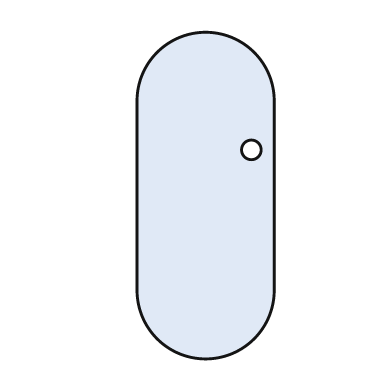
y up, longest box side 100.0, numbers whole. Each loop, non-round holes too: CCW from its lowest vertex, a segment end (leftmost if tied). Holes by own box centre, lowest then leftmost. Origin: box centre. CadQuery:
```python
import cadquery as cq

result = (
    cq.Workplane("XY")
    .moveTo(-21.0, -29.0)
    .threePointArc((0.0, -50.0), (21.0, -29.0))
    .lineTo(21.0, 29.0)
    .threePointArc((0.0, 50.0), (-21.0, 29.0))
    .close()
    .moveTo(14.0, 14.0)
    .circle(3.0)
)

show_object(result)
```